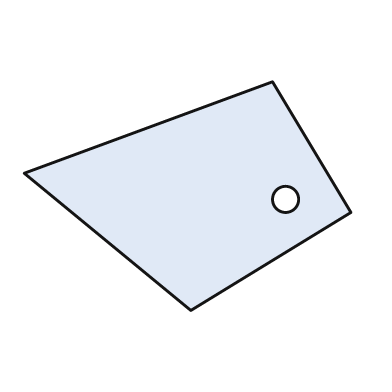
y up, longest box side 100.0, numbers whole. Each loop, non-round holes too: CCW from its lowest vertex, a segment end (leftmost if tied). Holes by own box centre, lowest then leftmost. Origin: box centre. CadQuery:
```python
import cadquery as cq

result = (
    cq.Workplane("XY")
    .moveTo(1.0, -35.0)
    .lineTo(50.0, -5.0)
    .lineTo(26.0, 35.0)
    .lineTo(-50.0, 7.0)
    .close()
    .moveTo(30.0, -1.0)
    .circle(4.0)
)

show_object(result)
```